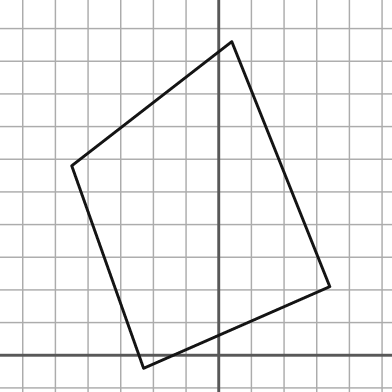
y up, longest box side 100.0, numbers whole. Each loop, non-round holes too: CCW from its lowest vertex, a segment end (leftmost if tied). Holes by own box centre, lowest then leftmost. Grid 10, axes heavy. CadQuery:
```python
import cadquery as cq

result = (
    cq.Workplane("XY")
    .moveTo(-23.0, -4.0)
    .lineTo(34.0, 21.0)
    .lineTo(4.0, 96.0)
    .lineTo(-45.0, 58.0)
    .close()
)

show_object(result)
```